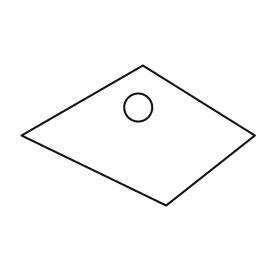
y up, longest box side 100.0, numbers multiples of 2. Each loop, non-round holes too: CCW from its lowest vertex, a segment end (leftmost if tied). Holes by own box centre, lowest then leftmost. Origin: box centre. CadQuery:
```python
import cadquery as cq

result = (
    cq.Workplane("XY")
    .moveTo(12.0, -30.0)
    .lineTo(50.0, 0.0)
    .lineTo(2.0, 30.0)
    .lineTo(-50.0, 0.0)
    .close()
    .moveTo(0.0, 12.0)
    .circle(6.0)
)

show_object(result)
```